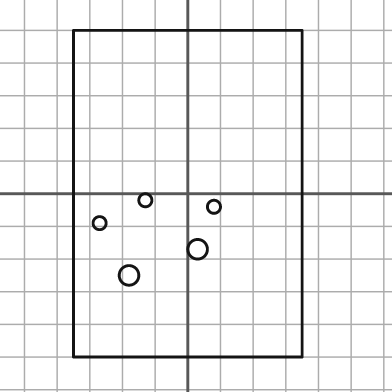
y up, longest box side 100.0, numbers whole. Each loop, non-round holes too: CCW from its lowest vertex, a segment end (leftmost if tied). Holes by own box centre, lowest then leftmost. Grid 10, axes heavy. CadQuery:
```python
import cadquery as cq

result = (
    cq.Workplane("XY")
    .moveTo(-35.0, -50.0)
    .lineTo(35.0, -50.0)
    .lineTo(35.0, 50.0)
    .lineTo(-35.0, 50.0)
    .close()
    .moveTo(-18.0, -25.0)
    .circle(3.0)
    .moveTo(3.0, -17.0)
    .circle(3.0)
    .moveTo(-27.0, -9.0)
    .circle(2.0)
    .moveTo(8.0, -4.0)
    .circle(2.0)
    .moveTo(-13.0, -2.0)
    .circle(2.0)
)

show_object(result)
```